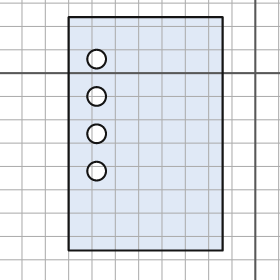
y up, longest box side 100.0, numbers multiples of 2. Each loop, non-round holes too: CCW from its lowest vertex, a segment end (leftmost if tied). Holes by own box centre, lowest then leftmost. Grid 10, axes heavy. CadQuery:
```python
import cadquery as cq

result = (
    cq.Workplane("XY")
    .moveTo(-80.0, -76.0)
    .lineTo(-14.0, -76.0)
    .lineTo(-14.0, 24.0)
    .lineTo(-80.0, 24.0)
    .close()
    .moveTo(-68.0, -42.0)
    .circle(4.0)
    .moveTo(-68.0, -26.0)
    .circle(4.0)
    .moveTo(-68.0, -10.0)
    .circle(4.0)
    .moveTo(-68.0, 6.0)
    .circle(4.0)
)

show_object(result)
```